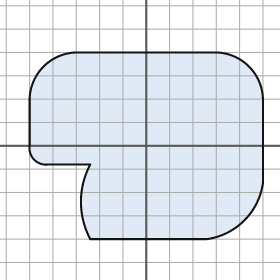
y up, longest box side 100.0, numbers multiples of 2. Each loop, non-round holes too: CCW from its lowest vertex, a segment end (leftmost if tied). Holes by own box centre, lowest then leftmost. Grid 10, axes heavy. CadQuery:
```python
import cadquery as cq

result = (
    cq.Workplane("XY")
    .moveTo(-24.0, -40.0)
    .lineTo(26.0, -40.0)
    .threePointArc((42.0, -32.0), (50.0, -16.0))
    .lineTo(50.0, 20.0)
    .threePointArc((44.0, 34.0), (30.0, 40.0))
    .lineTo(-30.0, 40.0)
    .threePointArc((-44.0, 34.0), (-50.0, 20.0))
    .lineTo(-50.0, 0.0)
    .threePointArc((-48.0, -6.0), (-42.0, -8.0))
    .lineTo(-24.0, -8.0)
    .threePointArc((-28.0, -24.0), (-24.0, -40.0))
    .close()
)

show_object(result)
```